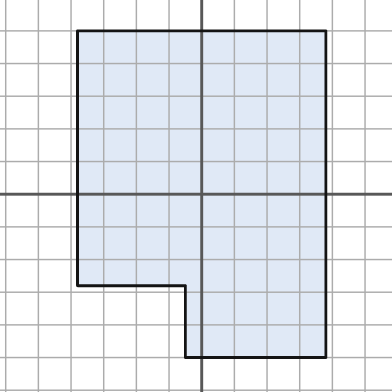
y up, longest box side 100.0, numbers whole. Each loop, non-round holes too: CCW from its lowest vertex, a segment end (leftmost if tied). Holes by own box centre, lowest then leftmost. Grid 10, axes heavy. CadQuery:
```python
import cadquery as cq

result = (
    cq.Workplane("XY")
    .moveTo(-5.0, -50.0)
    .lineTo(38.0, -50.0)
    .lineTo(38.0, 50.0)
    .lineTo(-38.0, 50.0)
    .lineTo(-38.0, -28.0)
    .lineTo(-5.0, -28.0)
    .close()
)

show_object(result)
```